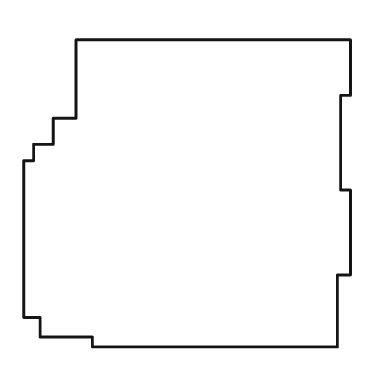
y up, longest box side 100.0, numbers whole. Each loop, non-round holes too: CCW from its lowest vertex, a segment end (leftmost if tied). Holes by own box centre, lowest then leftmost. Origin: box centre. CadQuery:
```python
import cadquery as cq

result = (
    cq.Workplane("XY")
    .moveTo(-29.0, -47.0)
    .lineTo(46.0, -47.0)
    .lineTo(46.0, -25.0)
    .lineTo(50.0, -25.0)
    .lineTo(50.0, 1.0)
    .lineTo(47.0, 1.0)
    .lineTo(47.0, 30.0)
    .lineTo(50.0, 30.0)
    .lineTo(50.0, 47.0)
    .lineTo(-34.0, 47.0)
    .lineTo(-34.0, 23.0)
    .lineTo(-41.0, 23.0)
    .lineTo(-41.0, 15.0)
    .lineTo(-47.0, 15.0)
    .lineTo(-47.0, 10.0)
    .lineTo(-50.0, 10.0)
    .lineTo(-50.0, -38.0)
    .lineTo(-45.0, -38.0)
    .lineTo(-45.0, -44.0)
    .lineTo(-29.0, -44.0)
    .close()
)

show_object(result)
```